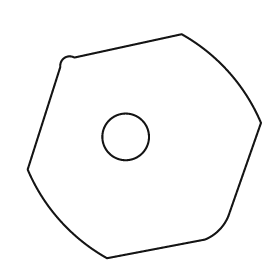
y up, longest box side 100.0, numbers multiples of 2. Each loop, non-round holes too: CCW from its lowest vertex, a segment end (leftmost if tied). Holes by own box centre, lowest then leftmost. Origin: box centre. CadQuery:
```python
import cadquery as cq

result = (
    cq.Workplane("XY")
    .moveTo(-16.0, -48.0)
    .lineTo(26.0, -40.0)
    .threePointArc((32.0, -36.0), (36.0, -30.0))
    .lineTo(50.0, 10.0)
    .threePointArc((36.0, 32.0), (16.0, 48.0))
    .lineTo(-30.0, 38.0)
    .threePointArc((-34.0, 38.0), (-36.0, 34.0))
    .lineTo(-50.0, -10.0)
    .threePointArc((-36.0, -32.0), (-16.0, -48.0))
    .close()
    .moveTo(-8.0, 4.0)
    .circle(10.0)
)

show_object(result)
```